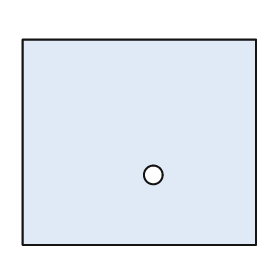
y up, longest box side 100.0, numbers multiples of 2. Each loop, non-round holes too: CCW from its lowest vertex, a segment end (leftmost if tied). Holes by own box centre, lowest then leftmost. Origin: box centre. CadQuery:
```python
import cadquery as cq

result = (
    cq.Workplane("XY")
    .moveTo(-50.0, -44.0)
    .lineTo(50.0, -44.0)
    .lineTo(50.0, 44.0)
    .lineTo(-50.0, 44.0)
    .close()
    .moveTo(6.0, -14.0)
    .circle(4.0)
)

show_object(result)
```